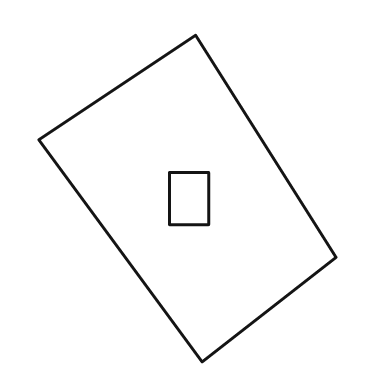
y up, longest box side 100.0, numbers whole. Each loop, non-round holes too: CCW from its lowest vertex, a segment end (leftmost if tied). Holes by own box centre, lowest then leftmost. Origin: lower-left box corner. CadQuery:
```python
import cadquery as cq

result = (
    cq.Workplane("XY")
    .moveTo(50.0, 0.0)
    .lineTo(91.0, 32.0)
    .lineTo(48.0, 100.0)
    .lineTo(0.0, 68.0)
    .close()
    .moveTo(40.0, 42.0)
    .lineTo(52.0, 42.0)
    .lineTo(52.0, 58.0)
    .lineTo(40.0, 58.0)
    .close()
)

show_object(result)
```